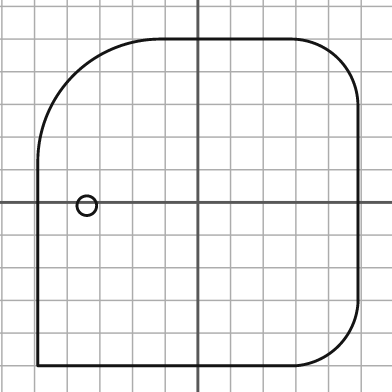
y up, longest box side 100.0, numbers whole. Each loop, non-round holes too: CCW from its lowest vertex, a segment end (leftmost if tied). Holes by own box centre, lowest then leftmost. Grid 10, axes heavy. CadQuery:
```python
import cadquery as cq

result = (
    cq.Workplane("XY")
    .moveTo(-49.0, -50.0)
    .lineTo(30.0, -50.0)
    .threePointArc((43.0, -44.0), (49.0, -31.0))
    .lineTo(49.0, 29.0)
    .threePointArc((43.0, 44.0), (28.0, 50.0))
    .lineTo(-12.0, 50.0)
    .threePointArc((-38.0, 39.0), (-49.0, 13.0))
    .close()
    .moveTo(-34.0, -1.0)
    .circle(3.0)
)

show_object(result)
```